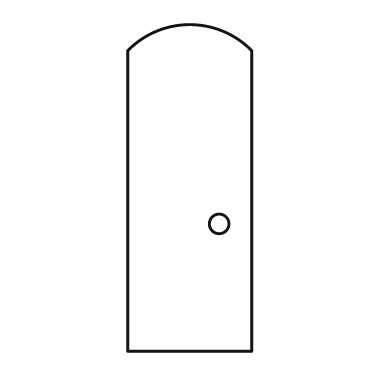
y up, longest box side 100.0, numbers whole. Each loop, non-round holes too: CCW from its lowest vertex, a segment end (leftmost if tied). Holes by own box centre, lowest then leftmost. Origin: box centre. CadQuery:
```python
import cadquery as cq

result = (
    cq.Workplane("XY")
    .moveTo(-19.0, -50.0)
    .lineTo(19.0, -50.0)
    .lineTo(19.0, 42.0)
    .threePointArc((0.0, 50.0), (-19.0, 42.0))
    .close()
    .moveTo(9.0, -11.0)
    .circle(3.0)
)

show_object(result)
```